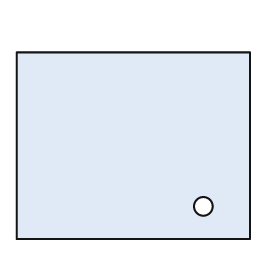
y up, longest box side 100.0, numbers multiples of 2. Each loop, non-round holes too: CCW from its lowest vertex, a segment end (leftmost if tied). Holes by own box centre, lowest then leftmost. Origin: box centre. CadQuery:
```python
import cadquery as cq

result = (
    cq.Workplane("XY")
    .moveTo(-50.0, -40.0)
    .lineTo(50.0, -40.0)
    .lineTo(50.0, 40.0)
    .lineTo(-50.0, 40.0)
    .close()
    .moveTo(30.0, -26.0)
    .circle(4.0)
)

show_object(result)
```